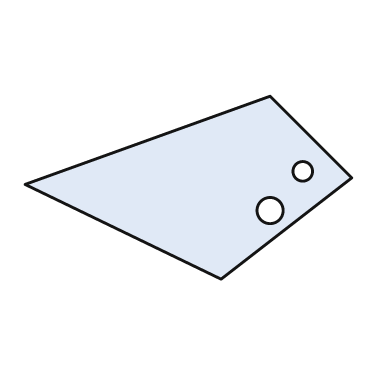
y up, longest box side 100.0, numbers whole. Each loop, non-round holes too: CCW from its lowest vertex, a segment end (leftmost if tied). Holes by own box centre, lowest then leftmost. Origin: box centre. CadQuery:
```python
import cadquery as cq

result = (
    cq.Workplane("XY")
    .moveTo(10.0, -28.0)
    .lineTo(50.0, 3.0)
    .lineTo(25.0, 28.0)
    .lineTo(-50.0, 1.0)
    .close()
    .moveTo(25.0, -7.0)
    .circle(4.0)
    .moveTo(35.0, 5.0)
    .circle(3.0)
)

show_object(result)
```